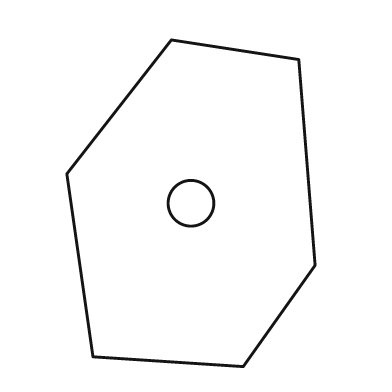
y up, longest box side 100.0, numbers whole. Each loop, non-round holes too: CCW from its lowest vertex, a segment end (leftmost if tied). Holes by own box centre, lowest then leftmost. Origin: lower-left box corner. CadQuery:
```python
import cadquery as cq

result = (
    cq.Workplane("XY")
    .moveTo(54.0, 0.0)
    .lineTo(76.0, 31.0)
    .lineTo(71.0, 94.0)
    .lineTo(32.0, 100.0)
    .lineTo(0.0, 59.0)
    .lineTo(8.0, 3.0)
    .close()
    .moveTo(38.0, 50.0)
    .circle(7.0)
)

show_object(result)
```